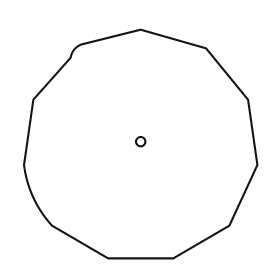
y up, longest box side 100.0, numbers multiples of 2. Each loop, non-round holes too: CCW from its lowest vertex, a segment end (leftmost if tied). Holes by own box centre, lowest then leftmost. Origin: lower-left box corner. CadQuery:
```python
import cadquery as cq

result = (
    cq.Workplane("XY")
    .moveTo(36.0, 0.0)
    .lineTo(64.0, 0.0)
    .lineTo(88.0, 14.0)
    .lineTo(100.0, 40.0)
    .lineTo(96.0, 68.0)
    .lineTo(78.0, 90.0)
    .lineTo(50.0, 98.0)
    .lineTo(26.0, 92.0)
    .threePointArc((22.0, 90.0), (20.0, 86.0))
    .lineTo(4.0, 68.0)
    .lineTo(0.0, 40.0)
    .threePointArc((4.0, 26.0), (12.0, 14.0))
    .close()
    .moveTo(50.0, 50.0)
    .circle(2.0)
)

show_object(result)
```